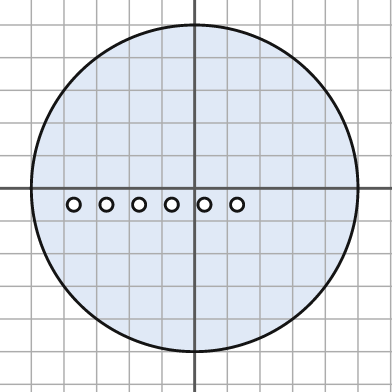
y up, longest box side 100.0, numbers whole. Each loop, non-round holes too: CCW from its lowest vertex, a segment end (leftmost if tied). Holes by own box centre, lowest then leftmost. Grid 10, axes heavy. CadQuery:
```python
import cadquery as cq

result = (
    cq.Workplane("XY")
    .moveTo(0.0, 0.0)
    .circle(50.0)
    .moveTo(-37.0, -5.0)
    .circle(2.0)
    .moveTo(-27.0, -5.0)
    .circle(2.0)
    .moveTo(-17.0, -5.0)
    .circle(2.0)
    .moveTo(-7.0, -5.0)
    .circle(2.0)
    .moveTo(3.0, -5.0)
    .circle(2.0)
    .moveTo(13.0, -5.0)
    .circle(2.0)
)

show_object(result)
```